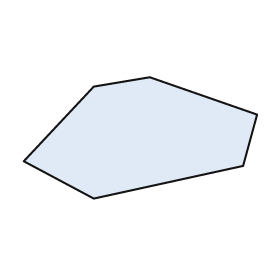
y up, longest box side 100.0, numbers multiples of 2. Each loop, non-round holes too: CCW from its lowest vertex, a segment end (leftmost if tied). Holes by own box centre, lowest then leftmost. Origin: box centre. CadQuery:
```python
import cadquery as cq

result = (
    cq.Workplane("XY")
    .moveTo(-20.0, -26.0)
    .lineTo(44.0, -12.0)
    .lineTo(50.0, 10.0)
    .lineTo(4.0, 26.0)
    .lineTo(-20.0, 22.0)
    .lineTo(-50.0, -10.0)
    .close()
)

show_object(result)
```